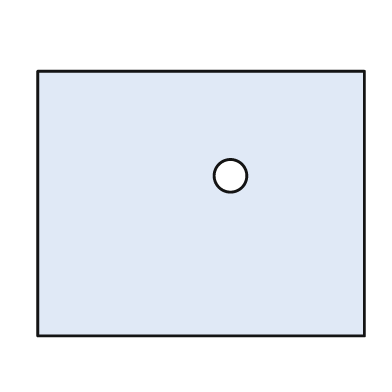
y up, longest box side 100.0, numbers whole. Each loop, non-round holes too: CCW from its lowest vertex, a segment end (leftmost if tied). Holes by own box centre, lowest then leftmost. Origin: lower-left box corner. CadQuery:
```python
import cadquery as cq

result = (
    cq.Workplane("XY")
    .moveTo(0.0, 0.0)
    .lineTo(100.0, 0.0)
    .lineTo(100.0, 81.0)
    .lineTo(0.0, 81.0)
    .close()
    .moveTo(59.0, 49.0)
    .circle(5.0)
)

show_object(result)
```